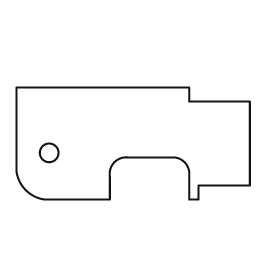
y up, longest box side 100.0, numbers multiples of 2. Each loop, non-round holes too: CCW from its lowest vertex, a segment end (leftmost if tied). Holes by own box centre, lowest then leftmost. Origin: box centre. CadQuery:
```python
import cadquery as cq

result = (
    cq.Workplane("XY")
    .moveTo(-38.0, -24.0)
    .lineTo(-10.0, -24.0)
    .lineTo(-10.0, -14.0)
    .threePointArc((-8.0, -8.0), (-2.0, -6.0))
    .lineTo(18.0, -6.0)
    .threePointArc((22.0, -8.0), (24.0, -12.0))
    .lineTo(24.0, -24.0)
    .lineTo(28.0, -24.0)
    .lineTo(28.0, -18.0)
    .lineTo(50.0, -18.0)
    .lineTo(50.0, 18.0)
    .lineTo(24.0, 18.0)
    .lineTo(24.0, 24.0)
    .lineTo(-50.0, 24.0)
    .lineTo(-50.0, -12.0)
    .threePointArc((-46.0, -20.0), (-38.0, -24.0))
    .close()
    .moveTo(-36.0, -4.0)
    .circle(4.0)
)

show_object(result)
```